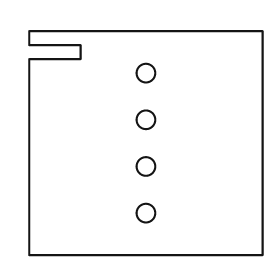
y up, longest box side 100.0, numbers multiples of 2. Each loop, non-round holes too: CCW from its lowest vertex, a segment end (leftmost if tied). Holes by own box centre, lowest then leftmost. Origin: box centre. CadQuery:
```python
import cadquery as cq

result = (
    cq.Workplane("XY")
    .moveTo(-50.0, -48.0)
    .lineTo(50.0, -48.0)
    .lineTo(50.0, 48.0)
    .lineTo(-50.0, 48.0)
    .lineTo(-50.0, 42.0)
    .lineTo(-28.0, 42.0)
    .lineTo(-28.0, 36.0)
    .lineTo(-50.0, 36.0)
    .close()
    .moveTo(0.0, -30.0)
    .circle(4.0)
    .moveTo(0.0, -10.0)
    .circle(4.0)
    .moveTo(0.0, 10.0)
    .circle(4.0)
    .moveTo(0.0, 30.0)
    .circle(4.0)
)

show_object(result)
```